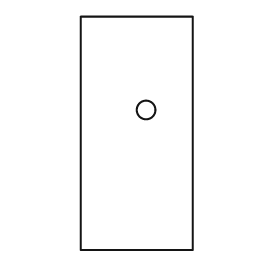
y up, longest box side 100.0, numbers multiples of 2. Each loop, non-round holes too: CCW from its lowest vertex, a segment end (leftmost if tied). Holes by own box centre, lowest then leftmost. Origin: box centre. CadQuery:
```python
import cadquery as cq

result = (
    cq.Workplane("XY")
    .moveTo(-24.0, -50.0)
    .lineTo(24.0, -50.0)
    .lineTo(24.0, 50.0)
    .lineTo(-24.0, 50.0)
    .close()
    .moveTo(4.0, 10.0)
    .circle(4.0)
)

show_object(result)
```